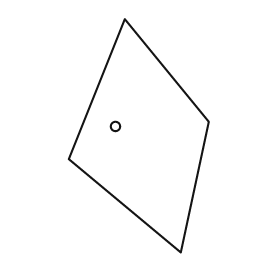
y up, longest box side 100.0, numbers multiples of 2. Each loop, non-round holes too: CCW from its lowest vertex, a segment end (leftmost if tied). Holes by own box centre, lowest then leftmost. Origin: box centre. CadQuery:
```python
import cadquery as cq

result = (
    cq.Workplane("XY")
    .moveTo(18.0, -50.0)
    .lineTo(30.0, 6.0)
    .lineTo(-6.0, 50.0)
    .lineTo(-30.0, -10.0)
    .close()
    .moveTo(-10.0, 4.0)
    .circle(2.0)
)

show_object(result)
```